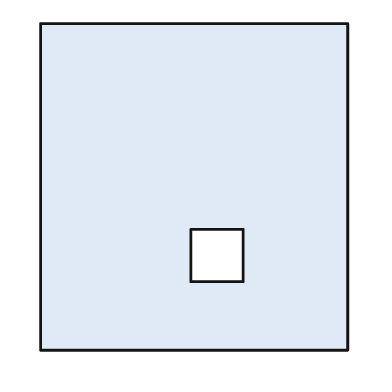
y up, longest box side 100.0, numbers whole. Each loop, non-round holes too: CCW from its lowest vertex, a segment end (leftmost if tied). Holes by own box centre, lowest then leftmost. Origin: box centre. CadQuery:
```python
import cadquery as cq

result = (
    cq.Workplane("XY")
    .moveTo(-47.0, -50.0)
    .lineTo(47.0, -50.0)
    .lineTo(47.0, 50.0)
    .lineTo(-47.0, 50.0)
    .close()
    .moveTo(-1.0, -29.0)
    .lineTo(15.0, -29.0)
    .lineTo(15.0, -13.0)
    .lineTo(-1.0, -13.0)
    .close()
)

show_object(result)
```